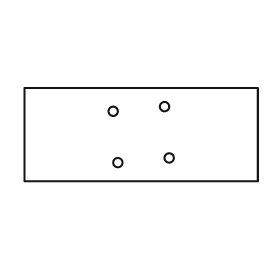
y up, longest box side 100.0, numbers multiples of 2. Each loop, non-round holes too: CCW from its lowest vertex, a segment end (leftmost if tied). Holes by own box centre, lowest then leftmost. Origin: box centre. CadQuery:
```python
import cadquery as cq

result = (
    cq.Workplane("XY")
    .moveTo(-50.0, -20.0)
    .lineTo(50.0, -20.0)
    .lineTo(50.0, 20.0)
    .lineTo(-50.0, 20.0)
    .close()
    .moveTo(-10.0, -12.0)
    .circle(2.0)
    .moveTo(12.0, -10.0)
    .circle(2.0)
    .moveTo(-12.0, 10.0)
    .circle(2.0)
    .moveTo(10.0, 12.0)
    .circle(2.0)
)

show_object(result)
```